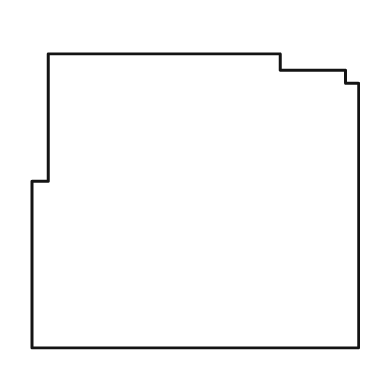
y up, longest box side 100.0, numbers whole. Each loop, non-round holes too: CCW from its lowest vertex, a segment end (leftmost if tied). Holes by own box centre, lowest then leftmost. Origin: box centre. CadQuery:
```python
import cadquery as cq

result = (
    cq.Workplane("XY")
    .moveTo(-50.0, -45.0)
    .lineTo(50.0, -45.0)
    .lineTo(50.0, 36.0)
    .lineTo(46.0, 36.0)
    .lineTo(46.0, 40.0)
    .lineTo(26.0, 40.0)
    .lineTo(26.0, 45.0)
    .lineTo(-45.0, 45.0)
    .lineTo(-45.0, 6.0)
    .lineTo(-50.0, 6.0)
    .close()
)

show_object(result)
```